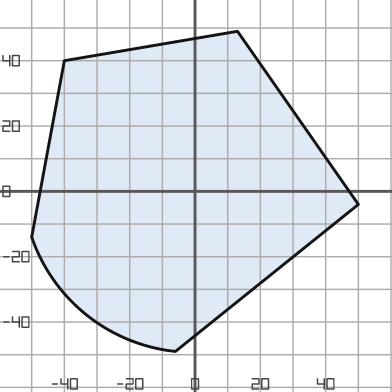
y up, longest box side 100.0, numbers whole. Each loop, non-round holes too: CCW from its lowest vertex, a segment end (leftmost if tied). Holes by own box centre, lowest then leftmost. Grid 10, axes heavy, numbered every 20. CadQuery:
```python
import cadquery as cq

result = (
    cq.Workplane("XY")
    .moveTo(-6.0, -49.0)
    .lineTo(50.0, -4.0)
    .lineTo(13.0, 49.0)
    .lineTo(-40.0, 40.0)
    .lineTo(-50.0, -14.0)
    .threePointArc((-33.0, -38.0), (-6.0, -49.0))
    .close()
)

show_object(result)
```